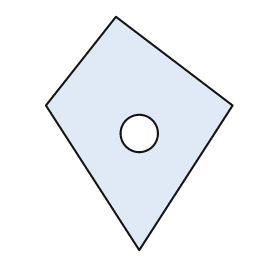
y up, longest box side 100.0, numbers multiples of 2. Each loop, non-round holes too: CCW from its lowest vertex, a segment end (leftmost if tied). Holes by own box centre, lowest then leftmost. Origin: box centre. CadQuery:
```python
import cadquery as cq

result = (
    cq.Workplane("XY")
    .moveTo(0.0, -50.0)
    .lineTo(40.0, 12.0)
    .lineTo(-10.0, 50.0)
    .lineTo(-40.0, 12.0)
    .close()
    .moveTo(0.0, 0.0)
    .circle(8.0)
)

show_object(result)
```